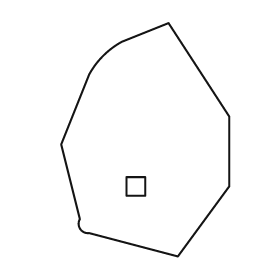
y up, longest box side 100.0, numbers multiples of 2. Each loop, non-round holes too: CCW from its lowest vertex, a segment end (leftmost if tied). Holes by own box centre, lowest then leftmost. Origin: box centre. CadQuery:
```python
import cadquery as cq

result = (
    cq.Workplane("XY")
    .moveTo(14.0, -50.0)
    .lineTo(36.0, -20.0)
    .lineTo(36.0, 10.0)
    .lineTo(10.0, 50.0)
    .lineTo(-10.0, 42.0)
    .threePointArc((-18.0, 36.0), (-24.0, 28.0))
    .lineTo(-36.0, -2.0)
    .lineTo(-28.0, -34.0)
    .threePointArc((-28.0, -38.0), (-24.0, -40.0))
    .close()
    .moveTo(-8.0, -24.0)
    .lineTo(0.0, -24.0)
    .lineTo(0.0, -16.0)
    .lineTo(-8.0, -16.0)
    .close()
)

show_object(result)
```